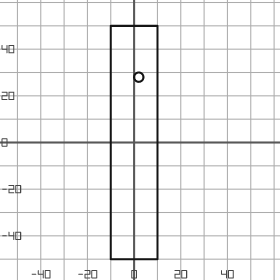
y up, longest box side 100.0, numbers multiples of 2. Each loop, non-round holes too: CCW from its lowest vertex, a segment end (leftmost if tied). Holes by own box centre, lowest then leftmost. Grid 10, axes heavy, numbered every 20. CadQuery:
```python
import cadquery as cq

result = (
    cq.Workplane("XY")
    .moveTo(-10.0, -50.0)
    .lineTo(10.0, -50.0)
    .lineTo(10.0, 50.0)
    .lineTo(-10.0, 50.0)
    .close()
    .moveTo(2.0, 28.0)
    .circle(2.0)
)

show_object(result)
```